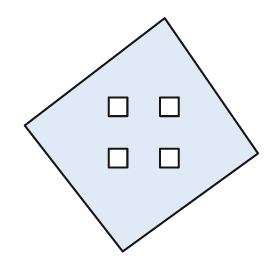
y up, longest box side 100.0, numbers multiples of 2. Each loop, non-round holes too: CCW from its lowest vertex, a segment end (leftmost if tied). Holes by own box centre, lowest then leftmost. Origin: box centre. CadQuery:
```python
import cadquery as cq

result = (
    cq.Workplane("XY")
    .moveTo(-8.0, -50.0)
    .lineTo(50.0, -8.0)
    .lineTo(10.0, 50.0)
    .lineTo(-50.0, 4.0)
    .close()
    .moveTo(-14.0, -14.0)
    .lineTo(-6.0, -14.0)
    .lineTo(-6.0, -6.0)
    .lineTo(-14.0, -6.0)
    .close()
    .moveTo(8.0, -14.0)
    .lineTo(16.0, -14.0)
    .lineTo(16.0, -6.0)
    .lineTo(8.0, -6.0)
    .close()
    .moveTo(-14.0, 8.0)
    .lineTo(-6.0, 8.0)
    .lineTo(-6.0, 16.0)
    .lineTo(-14.0, 16.0)
    .close()
    .moveTo(8.0, 8.0)
    .lineTo(16.0, 8.0)
    .lineTo(16.0, 16.0)
    .lineTo(8.0, 16.0)
    .close()
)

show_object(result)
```